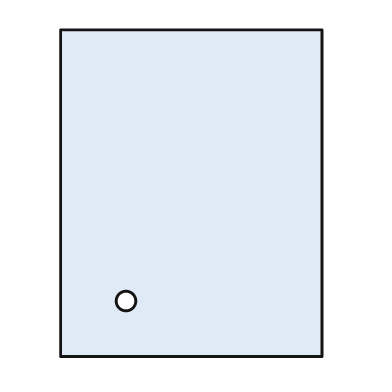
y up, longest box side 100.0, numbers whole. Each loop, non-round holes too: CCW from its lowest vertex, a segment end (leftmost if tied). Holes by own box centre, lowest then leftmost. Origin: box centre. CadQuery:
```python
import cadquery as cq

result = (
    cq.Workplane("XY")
    .moveTo(-40.0, -50.0)
    .lineTo(40.0, -50.0)
    .lineTo(40.0, 50.0)
    .lineTo(-40.0, 50.0)
    .close()
    .moveTo(-20.0, -33.0)
    .circle(3.0)
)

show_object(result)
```